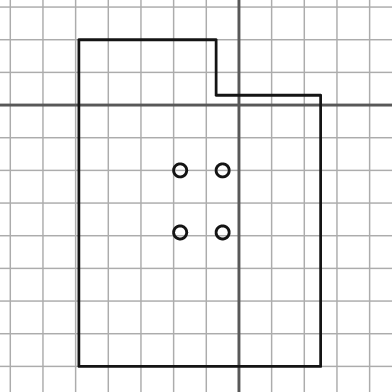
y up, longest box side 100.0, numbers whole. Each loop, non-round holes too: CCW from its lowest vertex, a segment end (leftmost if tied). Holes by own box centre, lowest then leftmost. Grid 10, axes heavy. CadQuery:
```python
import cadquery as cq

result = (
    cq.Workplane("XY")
    .moveTo(-49.0, -80.0)
    .lineTo(25.0, -80.0)
    .lineTo(25.0, 3.0)
    .lineTo(-7.0, 3.0)
    .lineTo(-7.0, 20.0)
    .lineTo(-49.0, 20.0)
    .close()
    .moveTo(-18.0, -39.0)
    .circle(2.0)
    .moveTo(-5.0, -39.0)
    .circle(2.0)
    .moveTo(-18.0, -20.0)
    .circle(2.0)
    .moveTo(-5.0, -20.0)
    .circle(2.0)
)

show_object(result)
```